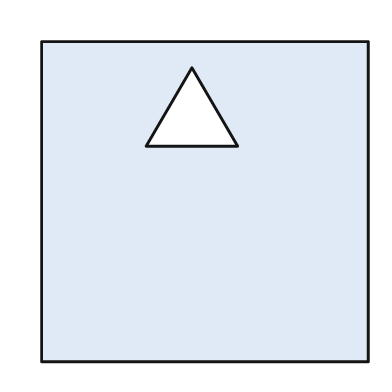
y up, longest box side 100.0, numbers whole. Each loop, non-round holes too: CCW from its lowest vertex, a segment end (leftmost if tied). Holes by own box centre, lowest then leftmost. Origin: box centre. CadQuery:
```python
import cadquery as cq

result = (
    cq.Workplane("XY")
    .moveTo(-50.0, -49.0)
    .lineTo(50.0, -49.0)
    .lineTo(50.0, 49.0)
    .lineTo(-50.0, 49.0)
    .close()
    .moveTo(-18.0, 17.0)
    .lineTo(10.0, 17.0)
    .lineTo(-4.0, 41.0)
    .close()
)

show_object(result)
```